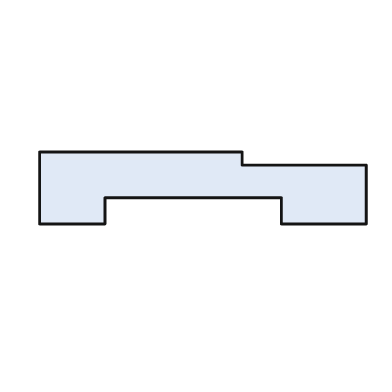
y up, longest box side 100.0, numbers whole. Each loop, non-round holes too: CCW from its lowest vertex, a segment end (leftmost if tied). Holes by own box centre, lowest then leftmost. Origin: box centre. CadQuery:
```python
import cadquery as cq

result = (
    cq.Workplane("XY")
    .moveTo(-50.0, -11.0)
    .lineTo(-30.0, -11.0)
    .lineTo(-30.0, -3.0)
    .lineTo(24.0, -3.0)
    .lineTo(24.0, -11.0)
    .lineTo(50.0, -11.0)
    .lineTo(50.0, 7.0)
    .lineTo(12.0, 7.0)
    .lineTo(12.0, 11.0)
    .lineTo(-50.0, 11.0)
    .close()
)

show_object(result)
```